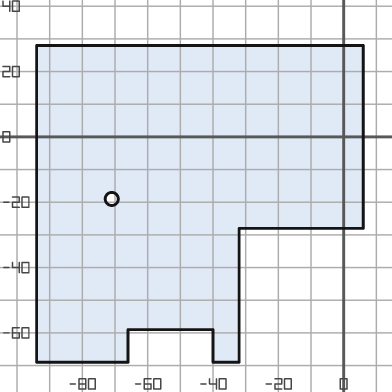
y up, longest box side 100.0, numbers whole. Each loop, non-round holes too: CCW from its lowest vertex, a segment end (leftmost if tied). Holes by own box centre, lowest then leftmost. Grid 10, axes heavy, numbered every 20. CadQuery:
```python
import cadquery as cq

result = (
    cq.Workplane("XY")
    .moveTo(-94.0, -69.0)
    .lineTo(-66.0, -69.0)
    .lineTo(-66.0, -59.0)
    .lineTo(-40.0, -59.0)
    .lineTo(-40.0, -69.0)
    .lineTo(-32.0, -69.0)
    .lineTo(-32.0, -28.0)
    .lineTo(6.0, -28.0)
    .lineTo(6.0, 28.0)
    .lineTo(-94.0, 28.0)
    .close()
    .moveTo(-71.0, -19.0)
    .circle(2.0)
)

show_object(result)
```